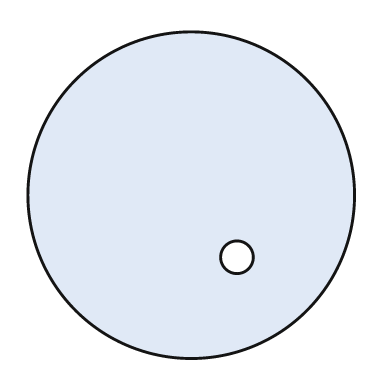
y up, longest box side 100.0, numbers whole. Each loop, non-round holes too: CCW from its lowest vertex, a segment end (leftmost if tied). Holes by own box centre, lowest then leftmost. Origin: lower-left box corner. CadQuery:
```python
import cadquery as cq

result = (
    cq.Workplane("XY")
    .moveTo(50.0, 50.0)
    .circle(50.0)
    .moveTo(64.0, 31.0)
    .circle(5.0)
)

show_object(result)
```